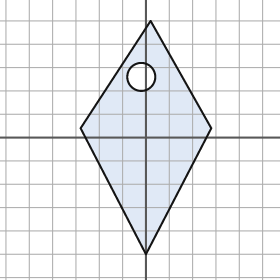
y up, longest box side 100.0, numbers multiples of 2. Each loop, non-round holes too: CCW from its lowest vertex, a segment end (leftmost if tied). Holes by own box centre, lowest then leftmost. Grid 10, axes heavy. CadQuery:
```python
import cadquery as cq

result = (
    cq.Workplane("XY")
    .moveTo(0.0, -50.0)
    .lineTo(28.0, 4.0)
    .lineTo(2.0, 50.0)
    .lineTo(-28.0, 4.0)
    .close()
    .moveTo(-2.0, 26.0)
    .circle(6.0)
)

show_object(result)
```